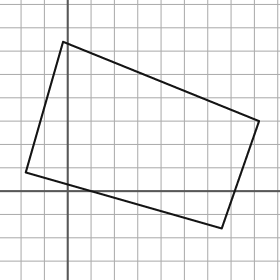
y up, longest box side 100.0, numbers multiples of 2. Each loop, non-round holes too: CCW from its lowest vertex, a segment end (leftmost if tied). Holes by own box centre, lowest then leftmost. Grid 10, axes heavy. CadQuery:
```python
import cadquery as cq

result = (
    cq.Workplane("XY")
    .moveTo(66.0, -16.0)
    .lineTo(82.0, 30.0)
    .lineTo(-2.0, 64.0)
    .lineTo(-18.0, 8.0)
    .close()
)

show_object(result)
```